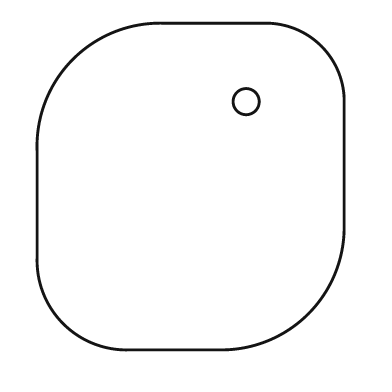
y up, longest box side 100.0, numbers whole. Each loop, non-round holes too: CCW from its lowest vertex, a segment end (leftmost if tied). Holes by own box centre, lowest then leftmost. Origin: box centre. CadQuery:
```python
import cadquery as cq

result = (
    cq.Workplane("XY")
    .moveTo(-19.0, -50.0)
    .lineTo(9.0, -50.0)
    .threePointArc((36.0, -39.0), (47.0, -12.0))
    .lineTo(47.0, 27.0)
    .threePointArc((40.0, 43.0), (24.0, 50.0))
    .lineTo(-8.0, 50.0)
    .threePointArc((-36.0, 39.0), (-47.0, 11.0))
    .lineTo(-47.0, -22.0)
    .threePointArc((-39.0, -42.0), (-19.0, -50.0))
    .close()
    .moveTo(17.0, 26.0)
    .circle(4.0)
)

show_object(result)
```